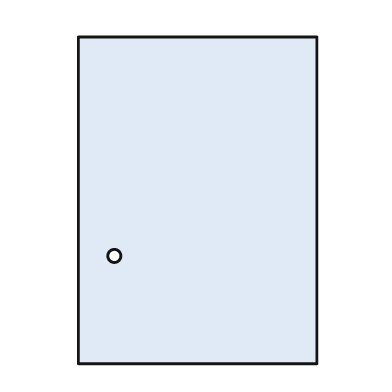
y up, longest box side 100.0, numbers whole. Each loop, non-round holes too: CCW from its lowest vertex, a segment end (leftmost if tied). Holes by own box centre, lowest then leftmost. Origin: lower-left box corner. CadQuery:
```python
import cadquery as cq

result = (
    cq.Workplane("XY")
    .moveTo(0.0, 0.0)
    .lineTo(73.0, 0.0)
    .lineTo(73.0, 100.0)
    .lineTo(0.0, 100.0)
    .close()
    .moveTo(11.0, 33.0)
    .circle(2.0)
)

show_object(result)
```